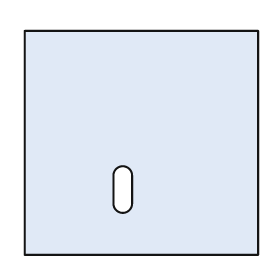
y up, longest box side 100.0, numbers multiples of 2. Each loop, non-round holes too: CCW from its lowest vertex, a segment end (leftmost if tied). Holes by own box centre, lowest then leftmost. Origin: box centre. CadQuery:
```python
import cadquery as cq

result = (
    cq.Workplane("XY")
    .moveTo(-50.0, -48.0)
    .lineTo(50.0, -48.0)
    .lineTo(50.0, 48.0)
    .lineTo(-50.0, 48.0)
    .close()
    .moveTo(-12.0, -26.0)
    .threePointArc((-8.0, -30.0), (-4.0, -26.0))
    .lineTo(-4.0, -14.0)
    .threePointArc((-8.0, -10.0), (-12.0, -14.0))
    .close()
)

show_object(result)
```